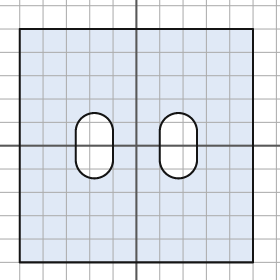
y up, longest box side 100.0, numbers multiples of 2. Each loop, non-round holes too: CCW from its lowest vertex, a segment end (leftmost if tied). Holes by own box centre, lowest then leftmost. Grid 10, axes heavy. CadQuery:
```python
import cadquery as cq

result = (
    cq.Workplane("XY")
    .moveTo(-50.0, -50.0)
    .lineTo(50.0, -50.0)
    .lineTo(50.0, 50.0)
    .lineTo(-50.0, 50.0)
    .close()
    .moveTo(-26.0, -6.0)
    .threePointArc((-18.0, -14.0), (-10.0, -6.0))
    .lineTo(-10.0, 6.0)
    .threePointArc((-18.0, 14.0), (-26.0, 6.0))
    .close()
    .moveTo(10.0, -6.0)
    .threePointArc((18.0, -14.0), (26.0, -6.0))
    .lineTo(26.0, 6.0)
    .threePointArc((18.0, 14.0), (10.0, 6.0))
    .close()
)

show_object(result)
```